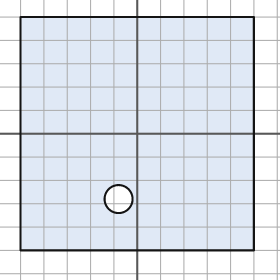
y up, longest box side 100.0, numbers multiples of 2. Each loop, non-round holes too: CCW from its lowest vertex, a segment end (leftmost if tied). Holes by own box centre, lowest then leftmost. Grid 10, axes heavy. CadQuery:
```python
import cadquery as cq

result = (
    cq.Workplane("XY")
    .moveTo(-50.0, -50.0)
    .lineTo(50.0, -50.0)
    .lineTo(50.0, 50.0)
    .lineTo(-50.0, 50.0)
    .close()
    .moveTo(-8.0, -28.0)
    .circle(6.0)
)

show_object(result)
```